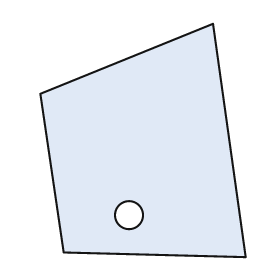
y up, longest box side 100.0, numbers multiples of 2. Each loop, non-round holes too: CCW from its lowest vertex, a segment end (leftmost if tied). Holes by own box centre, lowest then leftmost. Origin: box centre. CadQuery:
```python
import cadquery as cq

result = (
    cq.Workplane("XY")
    .moveTo(44.0, -50.0)
    .lineTo(30.0, 50.0)
    .lineTo(-44.0, 20.0)
    .lineTo(-34.0, -48.0)
    .close()
    .moveTo(-6.0, -32.0)
    .circle(6.0)
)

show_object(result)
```